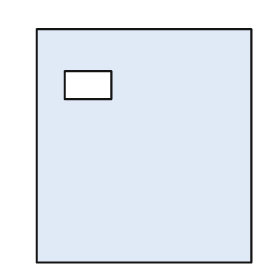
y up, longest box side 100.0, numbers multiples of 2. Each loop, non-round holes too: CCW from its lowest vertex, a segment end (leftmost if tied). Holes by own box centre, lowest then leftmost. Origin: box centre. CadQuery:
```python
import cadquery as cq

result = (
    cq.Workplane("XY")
    .moveTo(-46.0, -50.0)
    .lineTo(46.0, -50.0)
    .lineTo(46.0, 50.0)
    .lineTo(-46.0, 50.0)
    .close()
    .moveTo(-34.0, 20.0)
    .lineTo(-14.0, 20.0)
    .lineTo(-14.0, 32.0)
    .lineTo(-34.0, 32.0)
    .close()
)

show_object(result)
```